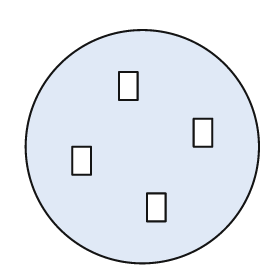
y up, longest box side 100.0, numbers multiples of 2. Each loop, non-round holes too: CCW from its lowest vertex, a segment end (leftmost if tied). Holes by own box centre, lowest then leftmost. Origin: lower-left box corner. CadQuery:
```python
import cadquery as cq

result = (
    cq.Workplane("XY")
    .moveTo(50.0, 50.0)
    .circle(50.0)
    .moveTo(52.0, 18.0)
    .lineTo(60.0, 18.0)
    .lineTo(60.0, 30.0)
    .lineTo(52.0, 30.0)
    .close()
    .moveTo(20.0, 38.0)
    .lineTo(28.0, 38.0)
    .lineTo(28.0, 50.0)
    .lineTo(20.0, 50.0)
    .close()
    .moveTo(72.0, 50.0)
    .lineTo(80.0, 50.0)
    .lineTo(80.0, 62.0)
    .lineTo(72.0, 62.0)
    .close()
    .moveTo(40.0, 70.0)
    .lineTo(48.0, 70.0)
    .lineTo(48.0, 82.0)
    .lineTo(40.0, 82.0)
    .close()
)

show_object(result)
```